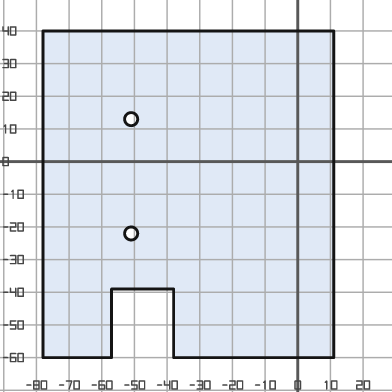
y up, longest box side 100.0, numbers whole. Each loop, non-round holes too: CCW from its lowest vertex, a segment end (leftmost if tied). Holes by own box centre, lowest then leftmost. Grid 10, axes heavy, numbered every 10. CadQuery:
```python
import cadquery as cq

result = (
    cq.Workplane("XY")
    .moveTo(-78.0, -60.0)
    .lineTo(-57.0, -60.0)
    .lineTo(-57.0, -39.0)
    .lineTo(-38.0, -39.0)
    .lineTo(-38.0, -60.0)
    .lineTo(11.0, -60.0)
    .lineTo(11.0, 40.0)
    .lineTo(-78.0, 40.0)
    .close()
    .moveTo(-51.0, -22.0)
    .circle(2.0)
    .moveTo(-51.0, 13.0)
    .circle(2.0)
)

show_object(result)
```